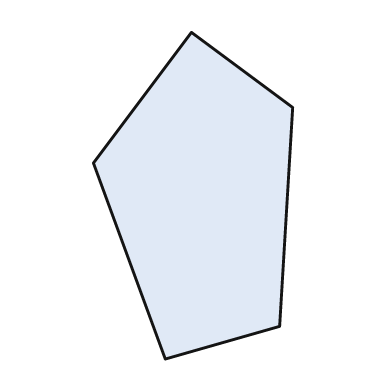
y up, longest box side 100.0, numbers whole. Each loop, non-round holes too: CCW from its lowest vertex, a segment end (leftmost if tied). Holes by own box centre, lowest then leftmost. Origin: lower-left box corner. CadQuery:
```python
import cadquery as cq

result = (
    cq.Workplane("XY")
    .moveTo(22.0, 0.0)
    .lineTo(57.0, 10.0)
    .lineTo(61.0, 77.0)
    .lineTo(30.0, 100.0)
    .lineTo(0.0, 60.0)
    .close()
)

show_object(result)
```